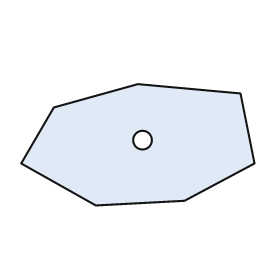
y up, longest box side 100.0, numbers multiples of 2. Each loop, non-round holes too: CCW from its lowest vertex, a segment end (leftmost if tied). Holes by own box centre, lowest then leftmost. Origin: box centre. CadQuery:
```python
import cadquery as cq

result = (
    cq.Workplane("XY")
    .moveTo(-18.0, -26.0)
    .lineTo(20.0, -24.0)
    .lineTo(50.0, -8.0)
    .lineTo(44.0, 22.0)
    .lineTo(0.0, 26.0)
    .lineTo(-36.0, 16.0)
    .lineTo(-50.0, -8.0)
    .close()
    .moveTo(2.0, 2.0)
    .circle(4.0)
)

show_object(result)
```